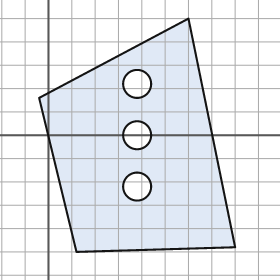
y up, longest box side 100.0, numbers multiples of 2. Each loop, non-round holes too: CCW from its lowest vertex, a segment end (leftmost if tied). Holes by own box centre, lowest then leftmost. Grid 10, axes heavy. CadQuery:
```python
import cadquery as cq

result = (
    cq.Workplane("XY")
    .moveTo(12.0, -50.0)
    .lineTo(80.0, -48.0)
    .lineTo(60.0, 50.0)
    .lineTo(-4.0, 16.0)
    .close()
    .moveTo(38.0, -22.0)
    .circle(6.0)
    .moveTo(38.0, 0.0)
    .circle(6.0)
    .moveTo(38.0, 22.0)
    .circle(6.0)
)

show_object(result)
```